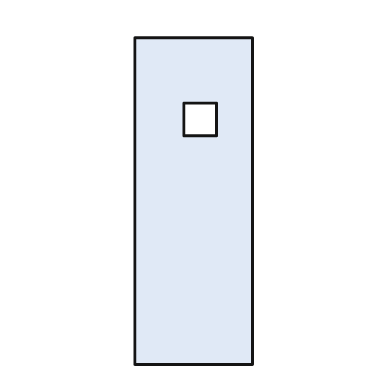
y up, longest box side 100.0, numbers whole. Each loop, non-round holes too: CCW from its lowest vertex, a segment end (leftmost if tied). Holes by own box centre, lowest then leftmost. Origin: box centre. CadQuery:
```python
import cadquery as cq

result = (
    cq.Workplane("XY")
    .moveTo(-18.0, -50.0)
    .lineTo(18.0, -50.0)
    .lineTo(18.0, 50.0)
    .lineTo(-18.0, 50.0)
    .close()
    .moveTo(-3.0, 20.0)
    .lineTo(7.0, 20.0)
    .lineTo(7.0, 30.0)
    .lineTo(-3.0, 30.0)
    .close()
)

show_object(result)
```